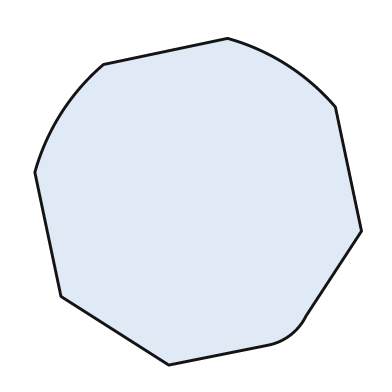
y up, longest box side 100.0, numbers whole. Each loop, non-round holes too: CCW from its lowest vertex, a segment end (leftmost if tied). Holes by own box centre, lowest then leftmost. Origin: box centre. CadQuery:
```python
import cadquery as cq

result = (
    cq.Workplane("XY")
    .moveTo(-9.0, -50.0)
    .lineTo(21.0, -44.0)
    .threePointArc((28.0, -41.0), (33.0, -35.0))
    .lineTo(50.0, -9.0)
    .lineTo(42.0, 29.0)
    .threePointArc((27.0, 42.0), (9.0, 50.0))
    .lineTo(-29.0, 42.0)
    .threePointArc((-42.0, 27.0), (-50.0, 9.0))
    .lineTo(-42.0, -29.0)
    .close()
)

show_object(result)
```